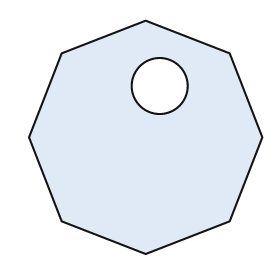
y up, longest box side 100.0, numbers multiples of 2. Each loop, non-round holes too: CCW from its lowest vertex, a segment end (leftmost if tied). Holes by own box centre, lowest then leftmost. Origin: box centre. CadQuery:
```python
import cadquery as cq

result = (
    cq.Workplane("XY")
    .moveTo(0.0, -50.0)
    .lineTo(36.0, -36.0)
    .lineTo(50.0, 0.0)
    .lineTo(36.0, 36.0)
    .lineTo(0.0, 50.0)
    .lineTo(-36.0, 36.0)
    .lineTo(-50.0, 0.0)
    .lineTo(-36.0, -36.0)
    .close()
    .moveTo(6.0, 22.0)
    .circle(12.0)
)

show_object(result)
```